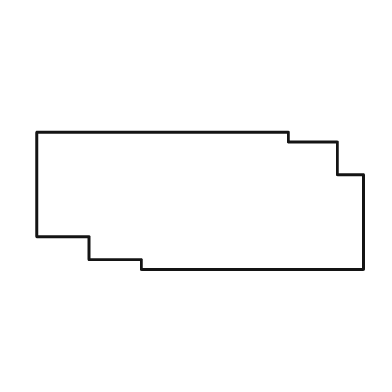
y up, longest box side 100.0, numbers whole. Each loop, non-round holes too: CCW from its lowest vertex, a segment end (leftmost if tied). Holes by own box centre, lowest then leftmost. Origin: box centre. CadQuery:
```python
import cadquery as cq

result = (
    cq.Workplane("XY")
    .moveTo(-18.0, -21.0)
    .lineTo(50.0, -21.0)
    .lineTo(50.0, 8.0)
    .lineTo(42.0, 8.0)
    .lineTo(42.0, 18.0)
    .lineTo(27.0, 18.0)
    .lineTo(27.0, 21.0)
    .lineTo(-50.0, 21.0)
    .lineTo(-50.0, -11.0)
    .lineTo(-34.0, -11.0)
    .lineTo(-34.0, -18.0)
    .lineTo(-18.0, -18.0)
    .close()
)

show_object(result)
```